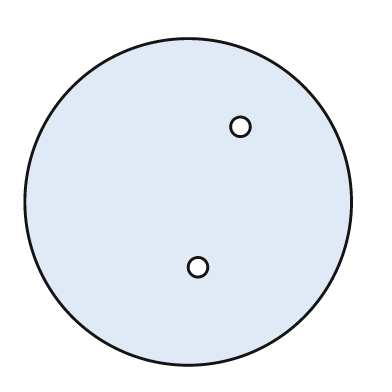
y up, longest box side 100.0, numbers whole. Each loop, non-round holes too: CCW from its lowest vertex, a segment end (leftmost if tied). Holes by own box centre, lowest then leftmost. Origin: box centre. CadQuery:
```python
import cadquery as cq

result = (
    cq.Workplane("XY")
    .moveTo(0.0, 0.0)
    .circle(50.0)
    .moveTo(3.0, -20.0)
    .circle(3.0)
    .moveTo(16.0, 23.0)
    .circle(3.0)
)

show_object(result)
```